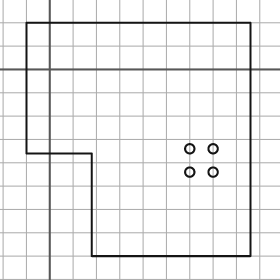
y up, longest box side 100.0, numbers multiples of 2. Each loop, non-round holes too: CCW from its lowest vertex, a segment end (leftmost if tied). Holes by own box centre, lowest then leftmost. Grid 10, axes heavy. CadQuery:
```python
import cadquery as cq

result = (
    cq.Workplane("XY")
    .moveTo(18.0, -80.0)
    .lineTo(86.0, -80.0)
    .lineTo(86.0, 20.0)
    .lineTo(-10.0, 20.0)
    .lineTo(-10.0, -36.0)
    .lineTo(18.0, -36.0)
    .close()
    .moveTo(60.0, -44.0)
    .circle(2.0)
    .moveTo(70.0, -44.0)
    .circle(2.0)
    .moveTo(60.0, -34.0)
    .circle(2.0)
    .moveTo(70.0, -34.0)
    .circle(2.0)
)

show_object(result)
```